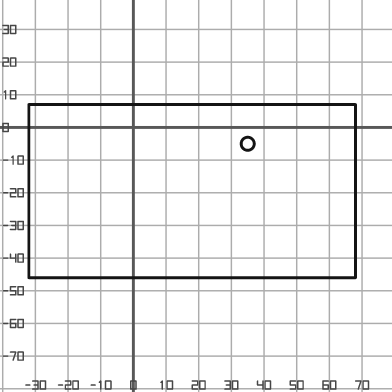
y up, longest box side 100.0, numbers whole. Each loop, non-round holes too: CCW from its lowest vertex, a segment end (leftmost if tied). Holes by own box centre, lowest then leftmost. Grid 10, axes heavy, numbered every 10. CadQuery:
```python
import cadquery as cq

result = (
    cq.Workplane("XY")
    .moveTo(-32.0, -46.0)
    .lineTo(68.0, -46.0)
    .lineTo(68.0, 7.0)
    .lineTo(-32.0, 7.0)
    .close()
    .moveTo(35.0, -5.0)
    .circle(2.0)
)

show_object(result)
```